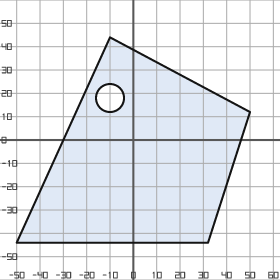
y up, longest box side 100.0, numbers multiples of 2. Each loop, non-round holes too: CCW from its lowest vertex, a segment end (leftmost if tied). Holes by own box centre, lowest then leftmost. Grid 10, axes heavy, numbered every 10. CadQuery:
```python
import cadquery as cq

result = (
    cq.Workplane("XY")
    .moveTo(-50.0, -44.0)
    .lineTo(32.0, -44.0)
    .lineTo(50.0, 12.0)
    .lineTo(-10.0, 44.0)
    .close()
    .moveTo(-10.0, 18.0)
    .circle(6.0)
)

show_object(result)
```